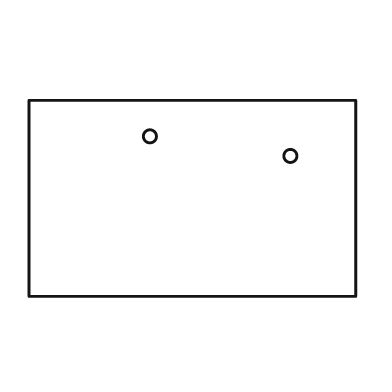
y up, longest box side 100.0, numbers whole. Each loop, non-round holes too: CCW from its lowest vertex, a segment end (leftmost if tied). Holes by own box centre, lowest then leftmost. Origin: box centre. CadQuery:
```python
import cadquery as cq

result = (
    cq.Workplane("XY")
    .moveTo(-50.0, -30.0)
    .lineTo(50.0, -30.0)
    .lineTo(50.0, 30.0)
    .lineTo(-50.0, 30.0)
    .close()
    .moveTo(30.0, 13.0)
    .circle(2.0)
    .moveTo(-13.0, 19.0)
    .circle(2.0)
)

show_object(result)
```